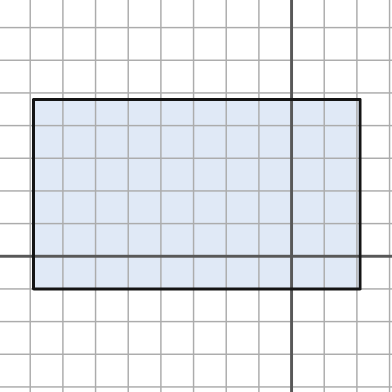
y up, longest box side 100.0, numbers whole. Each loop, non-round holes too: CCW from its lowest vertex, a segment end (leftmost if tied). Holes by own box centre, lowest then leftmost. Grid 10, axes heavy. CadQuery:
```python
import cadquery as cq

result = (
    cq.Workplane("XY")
    .moveTo(-79.0, -10.0)
    .lineTo(21.0, -10.0)
    .lineTo(21.0, 48.0)
    .lineTo(-79.0, 48.0)
    .close()
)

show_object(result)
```